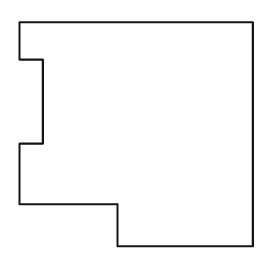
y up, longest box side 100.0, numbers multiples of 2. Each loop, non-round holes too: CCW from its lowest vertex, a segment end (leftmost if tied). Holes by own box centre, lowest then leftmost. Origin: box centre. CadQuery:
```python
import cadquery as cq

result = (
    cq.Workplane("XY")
    .moveTo(-8.0, -48.0)
    .lineTo(50.0, -48.0)
    .lineTo(50.0, 48.0)
    .lineTo(-50.0, 48.0)
    .lineTo(-50.0, 32.0)
    .lineTo(-40.0, 32.0)
    .lineTo(-40.0, -4.0)
    .lineTo(-50.0, -4.0)
    .lineTo(-50.0, -30.0)
    .lineTo(-8.0, -30.0)
    .close()
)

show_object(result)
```